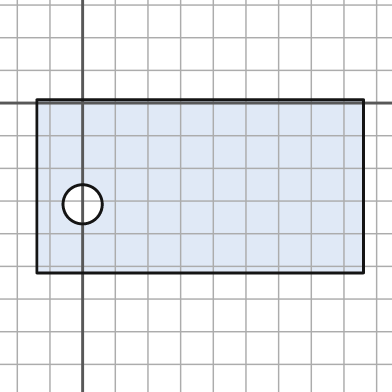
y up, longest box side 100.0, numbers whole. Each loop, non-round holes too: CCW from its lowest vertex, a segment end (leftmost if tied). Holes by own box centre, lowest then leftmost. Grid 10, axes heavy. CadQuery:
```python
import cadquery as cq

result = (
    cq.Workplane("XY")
    .moveTo(-14.0, -52.0)
    .lineTo(86.0, -52.0)
    .lineTo(86.0, 1.0)
    .lineTo(-14.0, 1.0)
    .close()
    .moveTo(0.0, -31.0)
    .circle(6.0)
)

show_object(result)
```